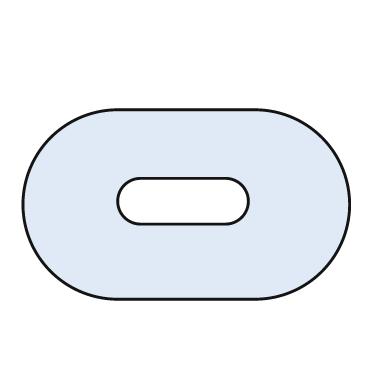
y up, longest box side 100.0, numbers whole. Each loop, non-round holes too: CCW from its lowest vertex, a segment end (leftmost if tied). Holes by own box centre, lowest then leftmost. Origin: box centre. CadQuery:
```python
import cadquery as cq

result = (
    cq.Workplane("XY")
    .moveTo(-21.0, -29.0)
    .lineTo(21.0, -29.0)
    .threePointArc((50.0, 0.0), (21.0, 29.0))
    .lineTo(-21.0, 29.0)
    .threePointArc((-50.0, 0.0), (-21.0, -29.0))
    .close()
    .moveTo(-14.0, -6.0)
    .lineTo(12.0, -6.0)
    .threePointArc((19.0, 1.0), (12.0, 8.0))
    .lineTo(-14.0, 8.0)
    .threePointArc((-21.0, 1.0), (-14.0, -6.0))
    .close()
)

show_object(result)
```